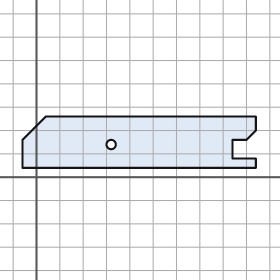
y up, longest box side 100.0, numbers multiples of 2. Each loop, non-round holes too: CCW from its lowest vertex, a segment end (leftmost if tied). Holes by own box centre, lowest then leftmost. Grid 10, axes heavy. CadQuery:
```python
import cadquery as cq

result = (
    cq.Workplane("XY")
    .moveTo(-6.0, 4.0)
    .lineTo(94.0, 4.0)
    .lineTo(94.0, 8.0)
    .lineTo(84.0, 8.0)
    .lineTo(84.0, 16.0)
    .lineTo(90.0, 16.0)
    .lineTo(94.0, 20.0)
    .lineTo(94.0, 26.0)
    .lineTo(4.0, 26.0)
    .lineTo(-6.0, 16.0)
    .close()
    .moveTo(32.0, 14.0)
    .circle(2.0)
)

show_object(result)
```